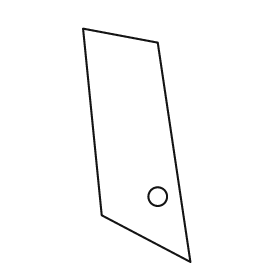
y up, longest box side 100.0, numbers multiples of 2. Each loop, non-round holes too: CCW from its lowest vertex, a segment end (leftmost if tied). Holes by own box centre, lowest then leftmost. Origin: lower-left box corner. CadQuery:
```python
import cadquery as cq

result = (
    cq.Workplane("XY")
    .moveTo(46.0, 0.0)
    .lineTo(32.0, 94.0)
    .lineTo(0.0, 100.0)
    .lineTo(8.0, 20.0)
    .close()
    .moveTo(32.0, 28.0)
    .circle(4.0)
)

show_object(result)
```